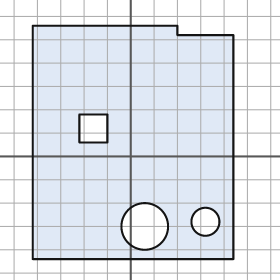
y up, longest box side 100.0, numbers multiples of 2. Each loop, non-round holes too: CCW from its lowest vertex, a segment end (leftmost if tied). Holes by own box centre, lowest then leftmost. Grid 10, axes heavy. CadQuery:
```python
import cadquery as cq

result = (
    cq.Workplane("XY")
    .moveTo(-42.0, -44.0)
    .lineTo(44.0, -44.0)
    .lineTo(44.0, 52.0)
    .lineTo(20.0, 52.0)
    .lineTo(20.0, 56.0)
    .lineTo(-42.0, 56.0)
    .close()
    .moveTo(6.0, -30.0)
    .circle(10.0)
    .moveTo(32.0, -28.0)
    .circle(6.0)
    .moveTo(-22.0, 6.0)
    .lineTo(-10.0, 6.0)
    .lineTo(-10.0, 18.0)
    .lineTo(-22.0, 18.0)
    .close()
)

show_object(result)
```